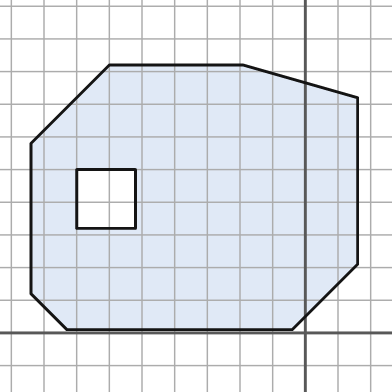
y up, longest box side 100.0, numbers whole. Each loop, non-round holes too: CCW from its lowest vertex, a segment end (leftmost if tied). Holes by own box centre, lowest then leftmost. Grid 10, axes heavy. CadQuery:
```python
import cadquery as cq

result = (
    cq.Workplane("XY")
    .moveTo(-73.0, 1.0)
    .lineTo(-4.0, 1.0)
    .lineTo(16.0, 21.0)
    .lineTo(16.0, 72.0)
    .lineTo(-19.0, 82.0)
    .lineTo(-60.0, 82.0)
    .lineTo(-84.0, 58.0)
    .lineTo(-84.0, 12.0)
    .close()
    .moveTo(-70.0, 32.0)
    .lineTo(-52.0, 32.0)
    .lineTo(-52.0, 50.0)
    .lineTo(-70.0, 50.0)
    .close()
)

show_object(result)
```